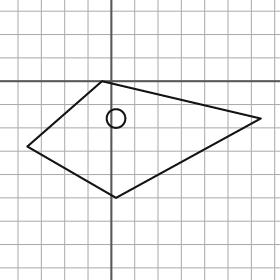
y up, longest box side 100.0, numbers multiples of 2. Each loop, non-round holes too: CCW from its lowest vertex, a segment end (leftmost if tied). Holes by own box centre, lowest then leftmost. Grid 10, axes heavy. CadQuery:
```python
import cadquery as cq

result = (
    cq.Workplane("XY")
    .moveTo(2.0, -50.0)
    .lineTo(64.0, -16.0)
    .lineTo(-4.0, 0.0)
    .lineTo(-36.0, -28.0)
    .close()
    .moveTo(2.0, -16.0)
    .circle(4.0)
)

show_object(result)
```